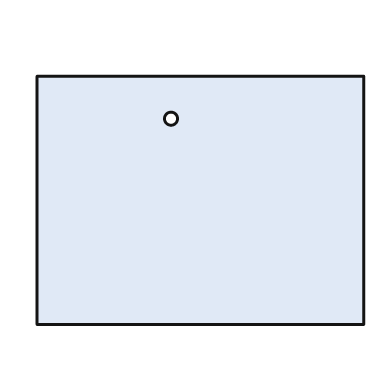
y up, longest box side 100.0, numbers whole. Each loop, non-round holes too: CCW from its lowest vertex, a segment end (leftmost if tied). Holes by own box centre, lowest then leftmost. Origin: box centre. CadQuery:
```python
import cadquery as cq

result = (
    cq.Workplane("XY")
    .moveTo(-50.0, -38.0)
    .lineTo(50.0, -38.0)
    .lineTo(50.0, 38.0)
    .lineTo(-50.0, 38.0)
    .close()
    .moveTo(-9.0, 25.0)
    .circle(2.0)
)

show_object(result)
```